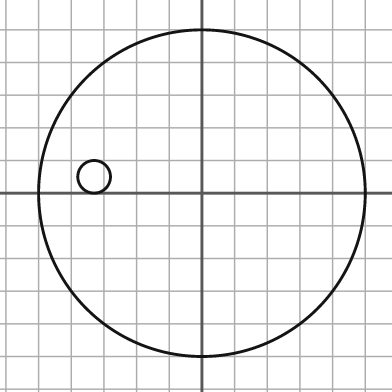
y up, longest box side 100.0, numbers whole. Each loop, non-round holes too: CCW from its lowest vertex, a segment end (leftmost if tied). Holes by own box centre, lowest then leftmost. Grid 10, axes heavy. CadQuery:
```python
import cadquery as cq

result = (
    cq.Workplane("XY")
    .moveTo(0.0, 0.0)
    .circle(50.0)
    .moveTo(-33.0, 5.0)
    .circle(5.0)
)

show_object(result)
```